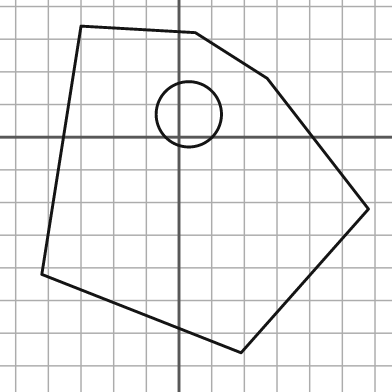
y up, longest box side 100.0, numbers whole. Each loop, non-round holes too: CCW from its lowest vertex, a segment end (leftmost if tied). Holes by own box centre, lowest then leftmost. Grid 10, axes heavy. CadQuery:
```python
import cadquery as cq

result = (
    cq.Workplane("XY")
    .moveTo(19.0, -66.0)
    .lineTo(58.0, -22.0)
    .lineTo(27.0, 18.0)
    .lineTo(5.0, 32.0)
    .lineTo(-30.0, 34.0)
    .lineTo(-42.0, -42.0)
    .close()
    .moveTo(3.0, 7.0)
    .circle(10.0)
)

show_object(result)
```